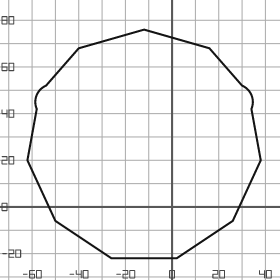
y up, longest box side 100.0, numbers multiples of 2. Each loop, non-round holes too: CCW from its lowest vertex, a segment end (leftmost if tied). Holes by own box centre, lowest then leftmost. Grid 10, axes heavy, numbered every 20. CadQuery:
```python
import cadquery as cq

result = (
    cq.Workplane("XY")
    .moveTo(-26.0, -22.0)
    .lineTo(2.0, -22.0)
    .lineTo(26.0, -6.0)
    .lineTo(38.0, 20.0)
    .lineTo(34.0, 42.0)
    .threePointArc((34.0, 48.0), (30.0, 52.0))
    .lineTo(16.0, 68.0)
    .lineTo(-12.0, 76.0)
    .lineTo(-40.0, 68.0)
    .lineTo(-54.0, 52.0)
    .threePointArc((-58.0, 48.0), (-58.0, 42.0))
    .lineTo(-62.0, 20.0)
    .lineTo(-50.0, -6.0)
    .close()
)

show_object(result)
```